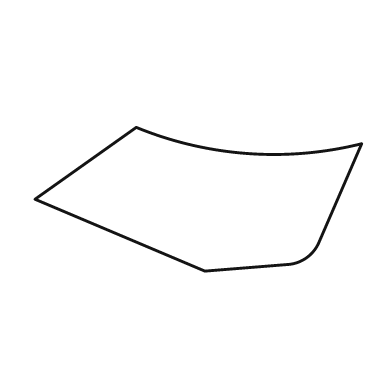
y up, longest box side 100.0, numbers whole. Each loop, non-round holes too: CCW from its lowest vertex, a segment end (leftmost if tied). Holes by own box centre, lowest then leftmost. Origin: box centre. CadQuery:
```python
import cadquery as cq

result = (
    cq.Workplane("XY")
    .moveTo(2.0, -22.0)
    .lineTo(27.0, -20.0)
    .threePointArc((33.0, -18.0), (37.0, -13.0))
    .lineTo(50.0, 17.0)
    .threePointArc((15.0, 14.0), (-19.0, 22.0))
    .lineTo(-50.0, 0.0)
    .close()
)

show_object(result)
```